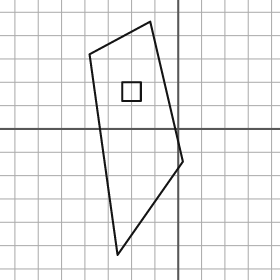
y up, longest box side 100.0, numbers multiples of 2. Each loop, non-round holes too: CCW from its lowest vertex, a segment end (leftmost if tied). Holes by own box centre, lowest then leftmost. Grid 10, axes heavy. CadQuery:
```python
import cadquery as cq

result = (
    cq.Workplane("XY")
    .moveTo(-26.0, -54.0)
    .lineTo(2.0, -14.0)
    .lineTo(-12.0, 46.0)
    .lineTo(-38.0, 32.0)
    .close()
    .moveTo(-24.0, 12.0)
    .lineTo(-16.0, 12.0)
    .lineTo(-16.0, 20.0)
    .lineTo(-24.0, 20.0)
    .close()
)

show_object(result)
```